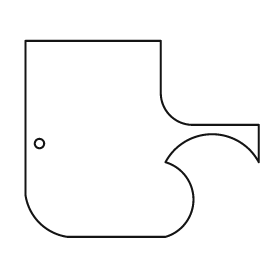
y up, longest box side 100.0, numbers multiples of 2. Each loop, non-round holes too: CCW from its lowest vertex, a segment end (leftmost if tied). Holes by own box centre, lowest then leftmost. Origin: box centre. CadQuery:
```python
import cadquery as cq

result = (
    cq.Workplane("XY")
    .moveTo(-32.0, -42.0)
    .lineTo(10.0, -42.0)
    .threePointArc((22.0, -26.0), (10.0, -10.0))
    .threePointArc((30.0, 2.0), (50.0, -10.0))
    .lineTo(50.0, 6.0)
    .lineTo(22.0, 6.0)
    .threePointArc((12.0, 10.0), (8.0, 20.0))
    .lineTo(8.0, 42.0)
    .lineTo(-50.0, 42.0)
    .lineTo(-50.0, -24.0)
    .threePointArc((-44.0, -36.0), (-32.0, -42.0))
    .close()
    .moveTo(-44.0, -2.0)
    .circle(2.0)
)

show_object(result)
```